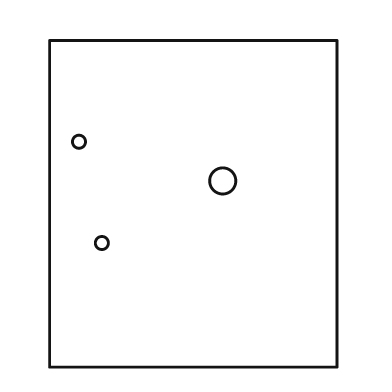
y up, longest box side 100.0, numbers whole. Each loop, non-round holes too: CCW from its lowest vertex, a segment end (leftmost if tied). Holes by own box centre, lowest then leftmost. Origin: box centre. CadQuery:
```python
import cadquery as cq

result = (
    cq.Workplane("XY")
    .moveTo(-44.0, -50.0)
    .lineTo(44.0, -50.0)
    .lineTo(44.0, 50.0)
    .lineTo(-44.0, 50.0)
    .close()
    .moveTo(-28.0, -12.0)
    .circle(2.0)
    .moveTo(9.0, 7.0)
    .circle(4.0)
    .moveTo(-35.0, 19.0)
    .circle(2.0)
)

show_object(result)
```